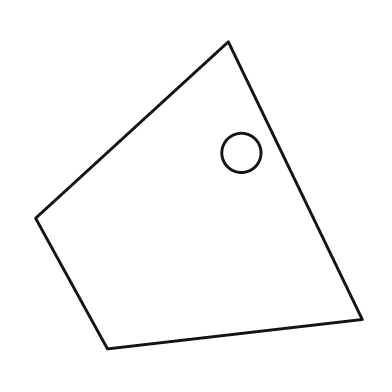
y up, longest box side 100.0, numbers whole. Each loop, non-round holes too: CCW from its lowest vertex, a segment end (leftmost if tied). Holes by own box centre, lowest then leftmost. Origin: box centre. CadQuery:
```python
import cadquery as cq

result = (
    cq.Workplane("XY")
    .moveTo(-28.0, -47.0)
    .lineTo(50.0, -38.0)
    .lineTo(9.0, 47.0)
    .lineTo(-50.0, -7.0)
    .close()
    .moveTo(13.0, 13.0)
    .circle(6.0)
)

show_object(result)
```